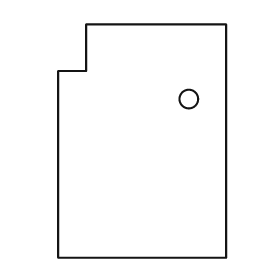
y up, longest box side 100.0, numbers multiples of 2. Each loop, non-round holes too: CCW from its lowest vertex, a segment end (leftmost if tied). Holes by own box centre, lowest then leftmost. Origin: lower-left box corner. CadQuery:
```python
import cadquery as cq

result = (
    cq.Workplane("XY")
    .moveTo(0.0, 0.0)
    .lineTo(72.0, 0.0)
    .lineTo(72.0, 100.0)
    .lineTo(12.0, 100.0)
    .lineTo(12.0, 80.0)
    .lineTo(0.0, 80.0)
    .close()
    .moveTo(56.0, 68.0)
    .circle(4.0)
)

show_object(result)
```